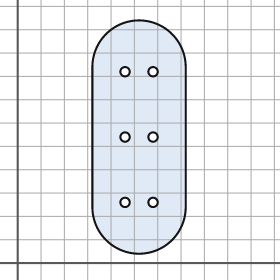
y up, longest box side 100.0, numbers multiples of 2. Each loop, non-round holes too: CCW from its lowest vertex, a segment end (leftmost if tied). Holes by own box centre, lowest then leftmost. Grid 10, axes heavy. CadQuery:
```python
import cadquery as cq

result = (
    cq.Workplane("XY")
    .moveTo(32.0, 24.0)
    .threePointArc((52.0, 4.0), (72.0, 24.0))
    .lineTo(72.0, 84.0)
    .threePointArc((52.0, 104.0), (32.0, 84.0))
    .close()
    .moveTo(46.0, 26.0)
    .circle(2.0)
    .moveTo(58.0, 26.0)
    .circle(2.0)
    .moveTo(46.0, 54.0)
    .circle(2.0)
    .moveTo(58.0, 54.0)
    .circle(2.0)
    .moveTo(46.0, 82.0)
    .circle(2.0)
    .moveTo(58.0, 82.0)
    .circle(2.0)
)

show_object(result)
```